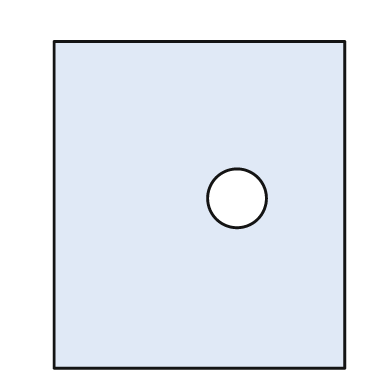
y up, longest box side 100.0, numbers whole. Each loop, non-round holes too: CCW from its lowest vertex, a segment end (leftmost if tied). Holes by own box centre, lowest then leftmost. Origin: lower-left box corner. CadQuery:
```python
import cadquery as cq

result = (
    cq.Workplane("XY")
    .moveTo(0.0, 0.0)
    .lineTo(89.0, 0.0)
    .lineTo(89.0, 100.0)
    .lineTo(0.0, 100.0)
    .close()
    .moveTo(56.0, 52.0)
    .circle(9.0)
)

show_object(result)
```